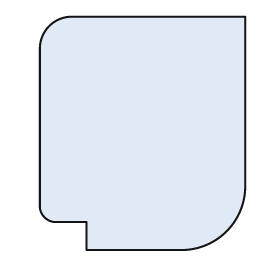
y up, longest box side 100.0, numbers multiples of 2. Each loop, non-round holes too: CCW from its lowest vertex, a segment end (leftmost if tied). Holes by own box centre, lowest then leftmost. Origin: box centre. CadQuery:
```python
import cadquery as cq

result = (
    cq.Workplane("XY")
    .moveTo(-24.0, -50.0)
    .lineTo(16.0, -50.0)
    .threePointArc((36.0, -42.0), (44.0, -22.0))
    .lineTo(44.0, 50.0)
    .lineTo(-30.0, 50.0)
    .threePointArc((-40.0, 46.0), (-44.0, 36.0))
    .lineTo(-44.0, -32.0)
    .threePointArc((-42.0, -36.0), (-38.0, -38.0))
    .lineTo(-24.0, -38.0)
    .close()
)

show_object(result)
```